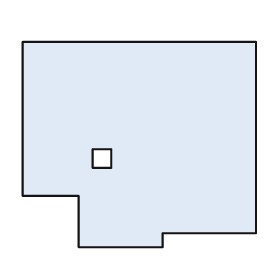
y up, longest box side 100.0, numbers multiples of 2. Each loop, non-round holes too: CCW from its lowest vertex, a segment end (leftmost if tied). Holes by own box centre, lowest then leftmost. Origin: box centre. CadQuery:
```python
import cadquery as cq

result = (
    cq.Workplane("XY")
    .moveTo(-26.0, -44.0)
    .lineTo(10.0, -44.0)
    .lineTo(10.0, -38.0)
    .lineTo(50.0, -38.0)
    .lineTo(50.0, 44.0)
    .lineTo(-50.0, 44.0)
    .lineTo(-50.0, -22.0)
    .lineTo(-26.0, -22.0)
    .close()
    .moveTo(-20.0, -10.0)
    .lineTo(-12.0, -10.0)
    .lineTo(-12.0, -2.0)
    .lineTo(-20.0, -2.0)
    .close()
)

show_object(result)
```